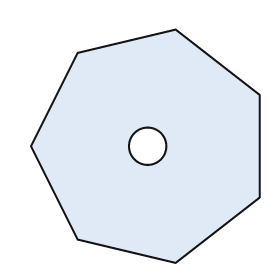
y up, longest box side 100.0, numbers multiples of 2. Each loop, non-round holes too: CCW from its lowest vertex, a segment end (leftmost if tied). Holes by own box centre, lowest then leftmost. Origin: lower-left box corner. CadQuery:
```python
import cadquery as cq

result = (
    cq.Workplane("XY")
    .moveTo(62.0, 0.0)
    .lineTo(98.0, 28.0)
    .lineTo(98.0, 72.0)
    .lineTo(62.0, 100.0)
    .lineTo(20.0, 90.0)
    .lineTo(0.0, 50.0)
    .lineTo(20.0, 10.0)
    .close()
    .moveTo(50.0, 50.0)
    .circle(8.0)
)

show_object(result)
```